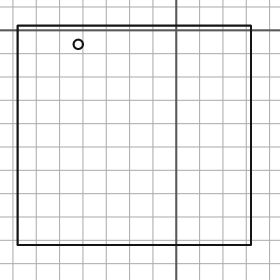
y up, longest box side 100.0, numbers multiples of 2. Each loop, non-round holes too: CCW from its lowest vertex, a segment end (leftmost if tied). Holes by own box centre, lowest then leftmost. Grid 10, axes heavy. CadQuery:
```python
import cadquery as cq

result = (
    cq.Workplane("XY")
    .moveTo(-68.0, -92.0)
    .lineTo(32.0, -92.0)
    .lineTo(32.0, 2.0)
    .lineTo(-68.0, 2.0)
    .close()
    .moveTo(-42.0, -6.0)
    .circle(2.0)
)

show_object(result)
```